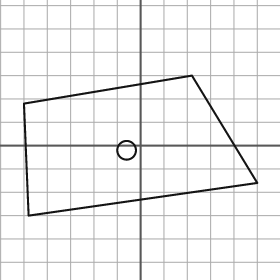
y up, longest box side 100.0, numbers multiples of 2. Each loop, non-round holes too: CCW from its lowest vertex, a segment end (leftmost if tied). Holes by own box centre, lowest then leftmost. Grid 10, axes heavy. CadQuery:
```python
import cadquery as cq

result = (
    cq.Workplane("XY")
    .moveTo(-48.0, -30.0)
    .lineTo(50.0, -16.0)
    .lineTo(22.0, 30.0)
    .lineTo(-50.0, 18.0)
    .close()
    .moveTo(-6.0, -2.0)
    .circle(4.0)
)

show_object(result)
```